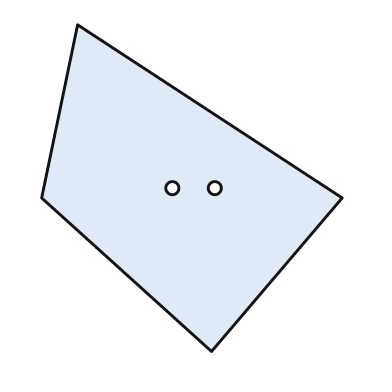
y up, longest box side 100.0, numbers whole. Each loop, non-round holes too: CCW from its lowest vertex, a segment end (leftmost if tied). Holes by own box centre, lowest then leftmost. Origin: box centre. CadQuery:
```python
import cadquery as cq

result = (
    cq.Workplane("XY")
    .moveTo(6.0, -50.0)
    .lineTo(46.0, -3.0)
    .lineTo(-35.0, 50.0)
    .lineTo(-46.0, -3.0)
    .close()
    .moveTo(-6.0, 0.0)
    .circle(2.0)
    .moveTo(7.0, 0.0)
    .circle(2.0)
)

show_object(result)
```